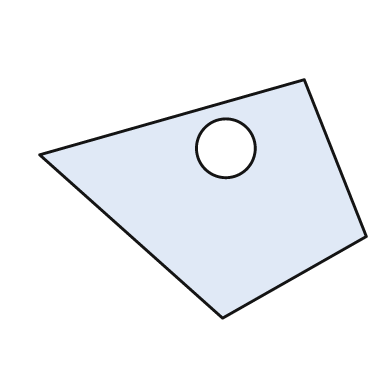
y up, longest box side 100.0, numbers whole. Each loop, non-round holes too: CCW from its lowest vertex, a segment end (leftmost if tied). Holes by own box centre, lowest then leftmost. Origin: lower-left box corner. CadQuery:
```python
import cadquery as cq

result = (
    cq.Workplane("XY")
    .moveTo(56.0, 0.0)
    .lineTo(100.0, 25.0)
    .lineTo(81.0, 73.0)
    .lineTo(0.0, 50.0)
    .close()
    .moveTo(57.0, 52.0)
    .circle(9.0)
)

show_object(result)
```